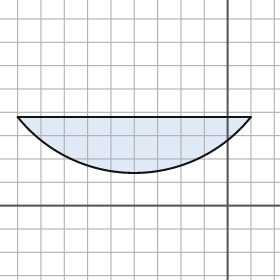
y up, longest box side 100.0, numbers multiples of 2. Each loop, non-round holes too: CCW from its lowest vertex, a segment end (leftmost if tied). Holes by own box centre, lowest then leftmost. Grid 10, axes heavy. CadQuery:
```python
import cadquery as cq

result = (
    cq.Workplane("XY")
    .moveTo(-90.0, 38.0)
    .threePointArc((-40.0, 14.0), (10.0, 38.0))
    .close()
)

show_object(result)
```